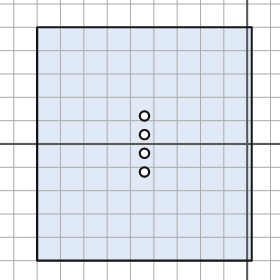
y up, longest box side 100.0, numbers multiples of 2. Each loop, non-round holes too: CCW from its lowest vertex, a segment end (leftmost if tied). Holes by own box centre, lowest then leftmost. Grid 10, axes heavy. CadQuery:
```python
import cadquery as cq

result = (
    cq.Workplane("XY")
    .moveTo(-90.0, -50.0)
    .lineTo(2.0, -50.0)
    .lineTo(2.0, 50.0)
    .lineTo(-90.0, 50.0)
    .close()
    .moveTo(-44.0, -12.0)
    .circle(2.0)
    .moveTo(-44.0, -4.0)
    .circle(2.0)
    .moveTo(-44.0, 4.0)
    .circle(2.0)
    .moveTo(-44.0, 12.0)
    .circle(2.0)
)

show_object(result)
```